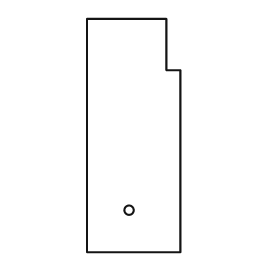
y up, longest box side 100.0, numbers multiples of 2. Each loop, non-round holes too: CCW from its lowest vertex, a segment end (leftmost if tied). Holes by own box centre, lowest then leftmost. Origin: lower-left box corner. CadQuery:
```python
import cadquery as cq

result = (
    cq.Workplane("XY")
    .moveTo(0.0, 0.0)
    .lineTo(40.0, 0.0)
    .lineTo(40.0, 78.0)
    .lineTo(34.0, 78.0)
    .lineTo(34.0, 100.0)
    .lineTo(0.0, 100.0)
    .close()
    .moveTo(18.0, 18.0)
    .circle(2.0)
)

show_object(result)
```